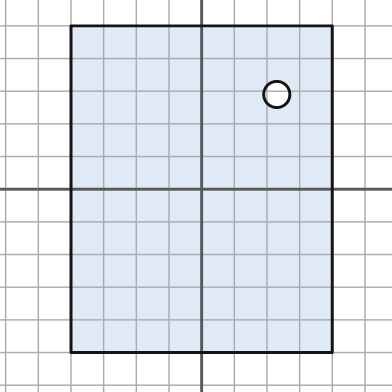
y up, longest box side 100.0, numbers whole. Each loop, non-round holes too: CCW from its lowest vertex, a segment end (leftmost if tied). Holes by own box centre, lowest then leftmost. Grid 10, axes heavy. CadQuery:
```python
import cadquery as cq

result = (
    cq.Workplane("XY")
    .moveTo(-40.0, -50.0)
    .lineTo(40.0, -50.0)
    .lineTo(40.0, 50.0)
    .lineTo(-40.0, 50.0)
    .close()
    .moveTo(23.0, 29.0)
    .circle(4.0)
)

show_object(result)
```